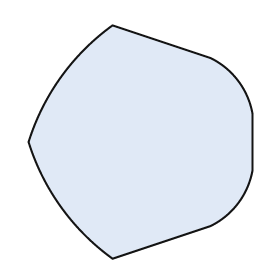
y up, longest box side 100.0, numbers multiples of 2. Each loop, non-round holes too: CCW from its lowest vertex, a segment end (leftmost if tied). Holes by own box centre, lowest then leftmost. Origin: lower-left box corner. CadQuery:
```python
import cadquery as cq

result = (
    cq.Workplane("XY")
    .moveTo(36.0, 0.0)
    .lineTo(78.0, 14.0)
    .threePointArc((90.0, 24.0), (96.0, 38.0))
    .lineTo(96.0, 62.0)
    .threePointArc((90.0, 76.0), (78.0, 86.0))
    .lineTo(36.0, 100.0)
    .threePointArc((14.0, 78.0), (0.0, 50.0))
    .threePointArc((14.0, 22.0), (36.0, 0.0))
    .close()
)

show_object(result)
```